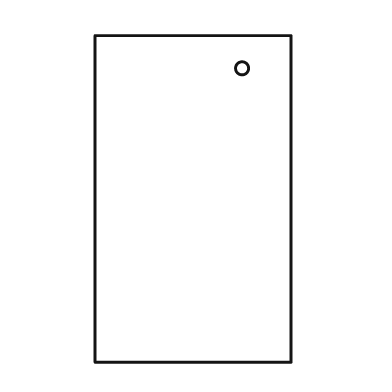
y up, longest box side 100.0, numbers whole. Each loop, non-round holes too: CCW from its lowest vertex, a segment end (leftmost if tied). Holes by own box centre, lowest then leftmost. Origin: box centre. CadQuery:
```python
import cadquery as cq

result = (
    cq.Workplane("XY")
    .moveTo(-30.0, -50.0)
    .lineTo(30.0, -50.0)
    .lineTo(30.0, 50.0)
    .lineTo(-30.0, 50.0)
    .close()
    .moveTo(15.0, 40.0)
    .circle(2.0)
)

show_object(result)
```